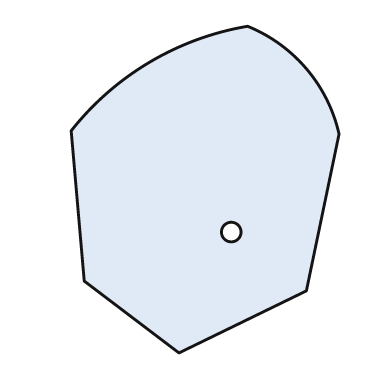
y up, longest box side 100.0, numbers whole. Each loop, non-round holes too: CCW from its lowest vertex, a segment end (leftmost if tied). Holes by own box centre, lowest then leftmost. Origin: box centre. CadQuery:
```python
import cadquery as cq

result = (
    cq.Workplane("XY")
    .moveTo(-8.0, -50.0)
    .lineTo(31.0, -31.0)
    .lineTo(41.0, 17.0)
    .threePointArc((31.0, 37.0), (13.0, 50.0))
    .threePointArc((-17.0, 39.0), (-41.0, 18.0))
    .lineTo(-37.0, -28.0)
    .close()
    .moveTo(8.0, -13.0)
    .circle(3.0)
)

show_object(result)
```